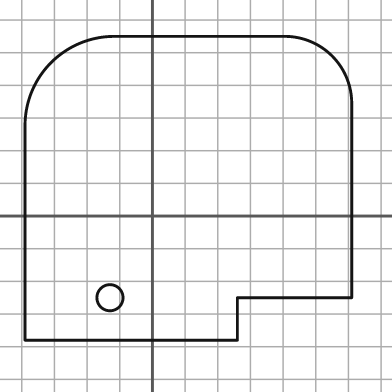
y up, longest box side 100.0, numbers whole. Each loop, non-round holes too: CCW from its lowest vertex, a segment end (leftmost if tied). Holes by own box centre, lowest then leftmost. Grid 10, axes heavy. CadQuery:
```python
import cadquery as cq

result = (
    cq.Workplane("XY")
    .moveTo(-39.0, -38.0)
    .lineTo(26.0, -38.0)
    .lineTo(26.0, -25.0)
    .lineTo(61.0, -25.0)
    .lineTo(61.0, 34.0)
    .threePointArc((55.0, 49.0), (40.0, 55.0))
    .lineTo(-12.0, 55.0)
    .threePointArc((-31.0, 47.0), (-39.0, 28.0))
    .close()
    .moveTo(-13.0, -25.0)
    .circle(4.0)
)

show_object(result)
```